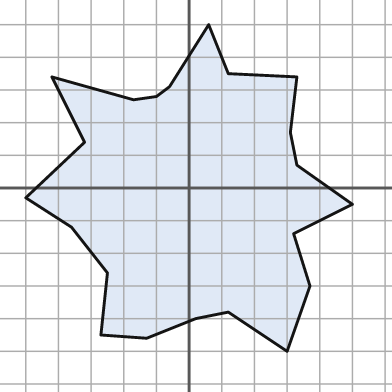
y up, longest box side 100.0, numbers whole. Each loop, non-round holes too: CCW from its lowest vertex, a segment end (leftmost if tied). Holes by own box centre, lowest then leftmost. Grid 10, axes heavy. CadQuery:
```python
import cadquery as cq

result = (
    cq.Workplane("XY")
    .moveTo(30.0, -50.0)
    .lineTo(37.0, -30.0)
    .lineTo(32.0, -14.0)
    .lineTo(50.0, -5.0)
    .lineTo(33.0, 7.0)
    .lineTo(31.0, 17.0)
    .lineTo(33.0, 34.0)
    .lineTo(12.0, 35.0)
    .lineTo(6.0, 50.0)
    .lineTo(-6.0, 31.0)
    .lineTo(-10.0, 28.0)
    .lineTo(-17.0, 27.0)
    .lineTo(-42.0, 34.0)
    .lineTo(-32.0, 14.0)
    .lineTo(-50.0, -3.0)
    .lineTo(-36.0, -12.0)
    .lineTo(-25.0, -26.0)
    .lineTo(-27.0, -45.0)
    .lineTo(-13.0, -46.0)
    .lineTo(2.0, -40.0)
    .lineTo(12.0, -38.0)
    .close()
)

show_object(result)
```